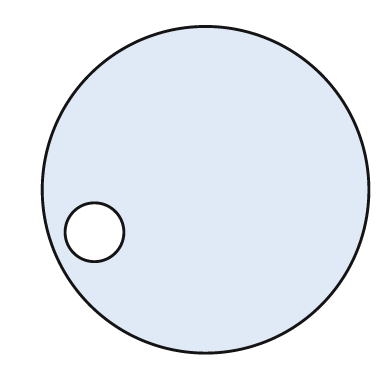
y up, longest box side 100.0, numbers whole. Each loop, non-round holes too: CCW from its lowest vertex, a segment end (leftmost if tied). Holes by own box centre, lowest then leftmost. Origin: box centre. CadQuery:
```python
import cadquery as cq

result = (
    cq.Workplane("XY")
    .moveTo(0.0, 0.0)
    .circle(50.0)
    .moveTo(-34.0, -13.0)
    .circle(9.0)
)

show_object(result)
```